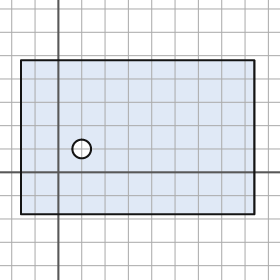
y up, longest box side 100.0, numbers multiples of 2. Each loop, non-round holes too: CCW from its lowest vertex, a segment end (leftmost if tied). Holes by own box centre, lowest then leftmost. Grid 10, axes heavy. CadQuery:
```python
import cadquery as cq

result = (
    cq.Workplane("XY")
    .moveTo(-16.0, -18.0)
    .lineTo(84.0, -18.0)
    .lineTo(84.0, 48.0)
    .lineTo(-16.0, 48.0)
    .close()
    .moveTo(10.0, 10.0)
    .circle(4.0)
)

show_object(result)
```